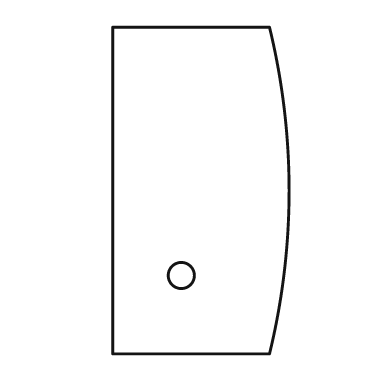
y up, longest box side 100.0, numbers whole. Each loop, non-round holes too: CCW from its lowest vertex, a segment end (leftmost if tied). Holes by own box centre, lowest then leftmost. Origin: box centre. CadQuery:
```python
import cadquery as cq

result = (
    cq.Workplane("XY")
    .moveTo(-27.0, -50.0)
    .lineTo(21.0, -50.0)
    .threePointArc((27.0, 0.0), (21.0, 50.0))
    .lineTo(-27.0, 50.0)
    .close()
    .moveTo(-6.0, -26.0)
    .circle(4.0)
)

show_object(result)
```